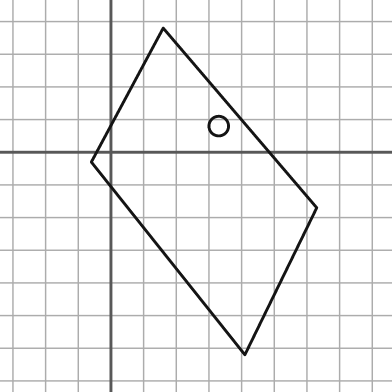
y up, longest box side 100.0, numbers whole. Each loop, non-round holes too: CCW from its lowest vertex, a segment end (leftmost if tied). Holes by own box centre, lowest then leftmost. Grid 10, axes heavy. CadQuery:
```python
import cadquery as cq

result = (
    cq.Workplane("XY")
    .moveTo(41.0, -62.0)
    .lineTo(63.0, -17.0)
    .lineTo(16.0, 38.0)
    .lineTo(-6.0, -3.0)
    .close()
    .moveTo(33.0, 8.0)
    .circle(3.0)
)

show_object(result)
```